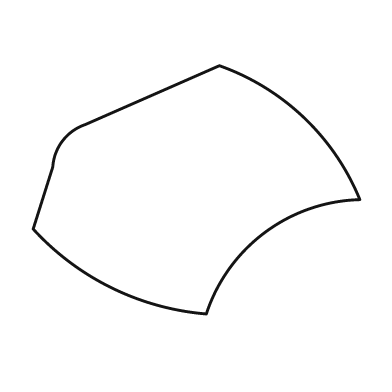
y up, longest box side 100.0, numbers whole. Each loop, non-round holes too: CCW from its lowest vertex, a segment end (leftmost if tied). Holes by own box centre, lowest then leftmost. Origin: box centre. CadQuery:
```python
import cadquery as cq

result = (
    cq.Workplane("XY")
    .moveTo(3.0, -38.0)
    .threePointArc((21.0, -13.0), (50.0, -3.0))
    .threePointArc((33.0, 22.0), (7.0, 38.0))
    .lineTo(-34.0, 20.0)
    .threePointArc((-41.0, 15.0), (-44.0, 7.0))
    .lineTo(-50.0, -12.0)
    .threePointArc((-26.0, -30.0), (3.0, -38.0))
    .close()
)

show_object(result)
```